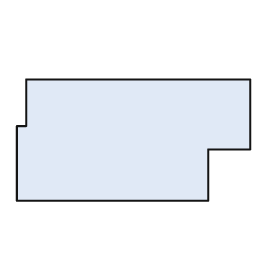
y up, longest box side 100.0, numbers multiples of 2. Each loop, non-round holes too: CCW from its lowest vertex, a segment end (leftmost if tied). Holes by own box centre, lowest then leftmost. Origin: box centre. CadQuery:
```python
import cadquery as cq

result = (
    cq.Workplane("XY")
    .moveTo(-50.0, -26.0)
    .lineTo(32.0, -26.0)
    .lineTo(32.0, -4.0)
    .lineTo(50.0, -4.0)
    .lineTo(50.0, 26.0)
    .lineTo(-46.0, 26.0)
    .lineTo(-46.0, 6.0)
    .lineTo(-50.0, 6.0)
    .close()
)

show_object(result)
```